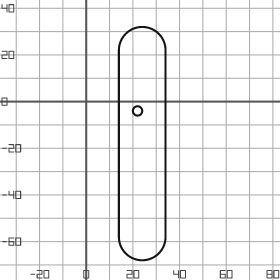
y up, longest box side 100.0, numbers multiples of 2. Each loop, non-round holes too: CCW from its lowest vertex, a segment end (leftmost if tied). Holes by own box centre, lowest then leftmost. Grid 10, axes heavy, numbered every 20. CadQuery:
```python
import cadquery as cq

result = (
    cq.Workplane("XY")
    .moveTo(14.0, -58.0)
    .threePointArc((24.0, -68.0), (34.0, -58.0))
    .lineTo(34.0, 22.0)
    .threePointArc((24.0, 32.0), (14.0, 22.0))
    .close()
    .moveTo(22.0, -4.0)
    .circle(2.0)
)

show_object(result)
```